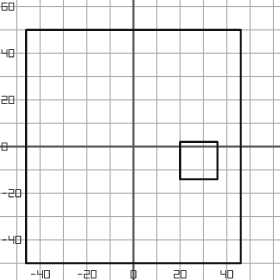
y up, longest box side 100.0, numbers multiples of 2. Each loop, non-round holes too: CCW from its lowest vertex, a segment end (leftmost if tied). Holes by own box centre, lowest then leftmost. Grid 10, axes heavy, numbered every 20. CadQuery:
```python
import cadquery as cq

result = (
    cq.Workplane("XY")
    .moveTo(-46.0, -50.0)
    .lineTo(46.0, -50.0)
    .lineTo(46.0, 50.0)
    .lineTo(-46.0, 50.0)
    .close()
    .moveTo(20.0, -14.0)
    .lineTo(36.0, -14.0)
    .lineTo(36.0, 2.0)
    .lineTo(20.0, 2.0)
    .close()
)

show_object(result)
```